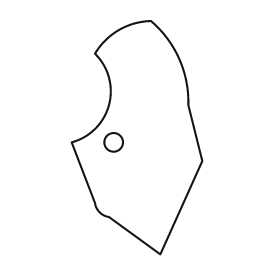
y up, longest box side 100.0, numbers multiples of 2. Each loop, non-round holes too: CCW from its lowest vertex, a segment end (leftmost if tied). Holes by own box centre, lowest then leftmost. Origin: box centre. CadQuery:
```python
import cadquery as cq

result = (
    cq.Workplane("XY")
    .moveTo(10.0, -50.0)
    .lineTo(28.0, -10.0)
    .lineTo(22.0, 14.0)
    .threePointArc((18.0, 34.0), (6.0, 50.0))
    .threePointArc((-8.0, 46.0), (-18.0, 36.0))
    .threePointArc((-12.0, 14.0), (-28.0, -2.0))
    .lineTo(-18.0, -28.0)
    .threePointArc((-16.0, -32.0), (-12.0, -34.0))
    .close()
    .moveTo(-10.0, -2.0)
    .circle(4.0)
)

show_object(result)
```